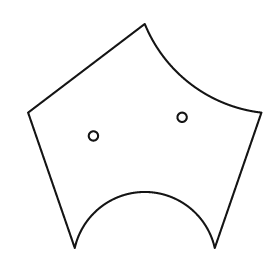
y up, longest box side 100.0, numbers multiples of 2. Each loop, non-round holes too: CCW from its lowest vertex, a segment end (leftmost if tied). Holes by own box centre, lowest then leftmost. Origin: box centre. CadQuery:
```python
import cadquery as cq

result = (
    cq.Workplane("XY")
    .moveTo(-30.0, -48.0)
    .threePointArc((0.0, -24.0), (30.0, -48.0))
    .lineTo(50.0, 10.0)
    .threePointArc((20.0, 22.0), (0.0, 48.0))
    .lineTo(-50.0, 10.0)
    .close()
    .moveTo(-22.0, 0.0)
    .circle(2.0)
    .moveTo(16.0, 8.0)
    .circle(2.0)
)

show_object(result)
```